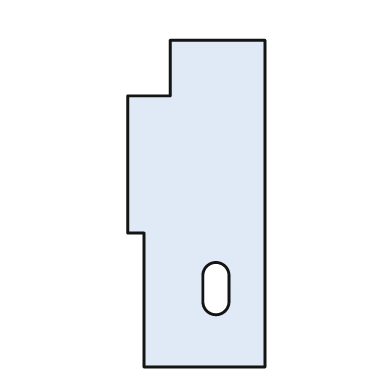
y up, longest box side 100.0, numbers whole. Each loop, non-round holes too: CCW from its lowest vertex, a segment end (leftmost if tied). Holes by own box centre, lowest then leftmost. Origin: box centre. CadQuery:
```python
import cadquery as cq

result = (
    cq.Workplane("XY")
    .moveTo(-16.0, -50.0)
    .lineTo(21.0, -50.0)
    .lineTo(21.0, 50.0)
    .lineTo(-8.0, 50.0)
    .lineTo(-8.0, 33.0)
    .lineTo(-21.0, 33.0)
    .lineTo(-21.0, -9.0)
    .lineTo(-16.0, -9.0)
    .close()
    .moveTo(2.0, -30.0)
    .threePointArc((6.0, -34.0), (10.0, -30.0))
    .lineTo(10.0, -22.0)
    .threePointArc((6.0, -18.0), (2.0, -22.0))
    .close()
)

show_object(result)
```